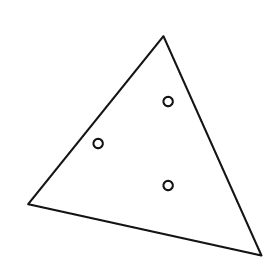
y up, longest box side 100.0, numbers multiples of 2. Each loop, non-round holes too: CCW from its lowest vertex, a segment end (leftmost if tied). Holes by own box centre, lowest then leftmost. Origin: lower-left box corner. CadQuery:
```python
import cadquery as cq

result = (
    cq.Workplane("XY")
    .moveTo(100.0, 0.0)
    .lineTo(58.0, 94.0)
    .lineTo(0.0, 22.0)
    .close()
    .moveTo(60.0, 30.0)
    .circle(2.0)
    .moveTo(30.0, 48.0)
    .circle(2.0)
    .moveTo(60.0, 66.0)
    .circle(2.0)
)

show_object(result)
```